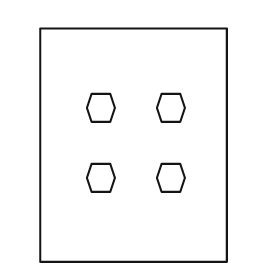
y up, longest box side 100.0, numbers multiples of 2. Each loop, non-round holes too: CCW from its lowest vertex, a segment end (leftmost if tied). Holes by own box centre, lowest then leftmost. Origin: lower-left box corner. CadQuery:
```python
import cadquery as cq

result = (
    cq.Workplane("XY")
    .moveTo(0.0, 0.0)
    .lineTo(80.0, 0.0)
    .lineTo(80.0, 100.0)
    .lineTo(0.0, 100.0)
    .close()
    .moveTo(22.0, 30.0)
    .lineTo(30.0, 30.0)
    .lineTo(32.0, 36.0)
    .lineTo(30.0, 42.0)
    .lineTo(22.0, 42.0)
    .lineTo(20.0, 36.0)
    .close()
    .moveTo(52.0, 30.0)
    .lineTo(60.0, 30.0)
    .lineTo(62.0, 36.0)
    .lineTo(60.0, 42.0)
    .lineTo(52.0, 42.0)
    .lineTo(50.0, 36.0)
    .close()
    .moveTo(22.0, 60.0)
    .lineTo(30.0, 60.0)
    .lineTo(32.0, 66.0)
    .lineTo(30.0, 72.0)
    .lineTo(22.0, 72.0)
    .lineTo(20.0, 66.0)
    .close()
    .moveTo(52.0, 60.0)
    .lineTo(60.0, 60.0)
    .lineTo(62.0, 66.0)
    .lineTo(60.0, 72.0)
    .lineTo(52.0, 72.0)
    .lineTo(50.0, 66.0)
    .close()
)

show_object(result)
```